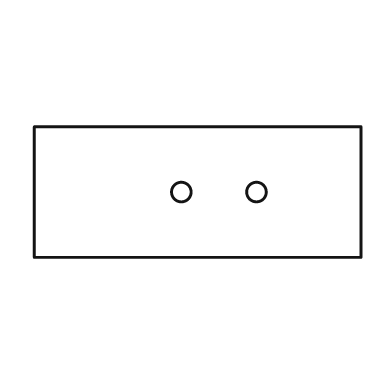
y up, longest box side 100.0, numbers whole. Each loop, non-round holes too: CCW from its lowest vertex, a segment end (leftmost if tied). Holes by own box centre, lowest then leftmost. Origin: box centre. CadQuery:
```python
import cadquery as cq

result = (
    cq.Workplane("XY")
    .moveTo(-50.0, -20.0)
    .lineTo(50.0, -20.0)
    .lineTo(50.0, 20.0)
    .lineTo(-50.0, 20.0)
    .close()
    .moveTo(-5.0, 0.0)
    .circle(3.0)
    .moveTo(18.0, 0.0)
    .circle(3.0)
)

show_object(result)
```